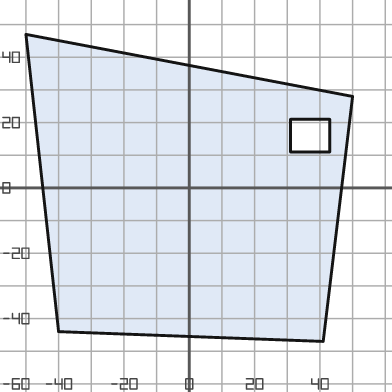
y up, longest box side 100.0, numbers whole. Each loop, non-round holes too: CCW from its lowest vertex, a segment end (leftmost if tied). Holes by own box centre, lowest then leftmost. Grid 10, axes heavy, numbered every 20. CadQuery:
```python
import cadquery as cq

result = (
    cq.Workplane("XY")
    .moveTo(41.0, -47.0)
    .lineTo(50.0, 28.0)
    .lineTo(-50.0, 47.0)
    .lineTo(-40.0, -44.0)
    .close()
    .moveTo(31.0, 11.0)
    .lineTo(43.0, 11.0)
    .lineTo(43.0, 21.0)
    .lineTo(31.0, 21.0)
    .close()
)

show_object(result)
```